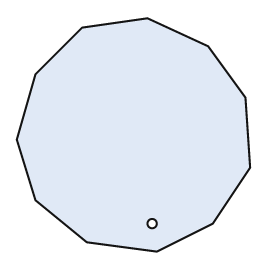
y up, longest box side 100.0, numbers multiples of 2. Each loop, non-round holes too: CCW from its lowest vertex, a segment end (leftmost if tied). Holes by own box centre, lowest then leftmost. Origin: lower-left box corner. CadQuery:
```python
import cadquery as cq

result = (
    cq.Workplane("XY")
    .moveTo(60.0, 0.0)
    .lineTo(84.0, 12.0)
    .lineTo(100.0, 36.0)
    .lineTo(98.0, 66.0)
    .lineTo(82.0, 88.0)
    .lineTo(56.0, 100.0)
    .lineTo(28.0, 96.0)
    .lineTo(8.0, 76.0)
    .lineTo(0.0, 48.0)
    .lineTo(8.0, 22.0)
    .lineTo(30.0, 4.0)
    .close()
    .moveTo(58.0, 12.0)
    .circle(2.0)
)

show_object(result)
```